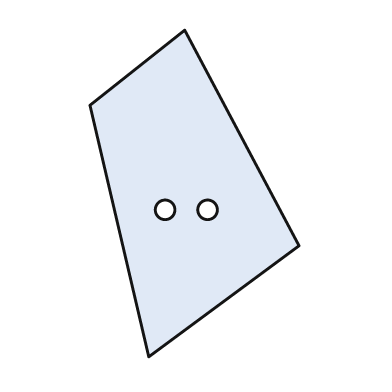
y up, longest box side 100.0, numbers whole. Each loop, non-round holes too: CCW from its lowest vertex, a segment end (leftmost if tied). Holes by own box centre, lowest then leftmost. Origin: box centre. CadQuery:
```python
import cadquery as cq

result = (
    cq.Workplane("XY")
    .moveTo(-14.0, -50.0)
    .lineTo(32.0, -16.0)
    .lineTo(-3.0, 50.0)
    .lineTo(-32.0, 27.0)
    .close()
    .moveTo(-9.0, -5.0)
    .circle(3.0)
    .moveTo(4.0, -5.0)
    .circle(3.0)
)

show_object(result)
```